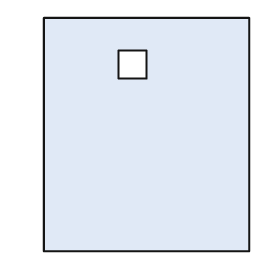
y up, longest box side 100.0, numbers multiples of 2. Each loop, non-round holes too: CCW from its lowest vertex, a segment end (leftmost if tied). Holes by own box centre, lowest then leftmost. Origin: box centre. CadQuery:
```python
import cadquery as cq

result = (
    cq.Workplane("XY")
    .moveTo(-44.0, -50.0)
    .lineTo(44.0, -50.0)
    .lineTo(44.0, 50.0)
    .lineTo(-44.0, 50.0)
    .close()
    .moveTo(-12.0, 24.0)
    .lineTo(0.0, 24.0)
    .lineTo(0.0, 36.0)
    .lineTo(-12.0, 36.0)
    .close()
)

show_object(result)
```